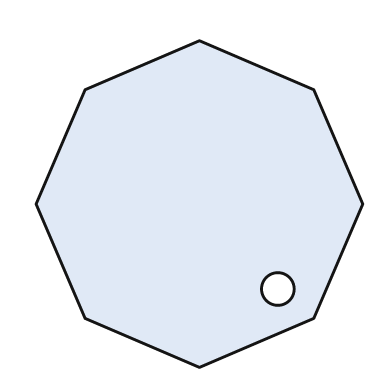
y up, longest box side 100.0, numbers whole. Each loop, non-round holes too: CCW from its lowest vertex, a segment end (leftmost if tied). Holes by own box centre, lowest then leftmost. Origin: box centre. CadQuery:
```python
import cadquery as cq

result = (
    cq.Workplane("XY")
    .moveTo(0.0, -50.0)
    .lineTo(35.0, -35.0)
    .lineTo(50.0, 0.0)
    .lineTo(35.0, 35.0)
    .lineTo(0.0, 50.0)
    .lineTo(-35.0, 35.0)
    .lineTo(-50.0, 0.0)
    .lineTo(-35.0, -35.0)
    .close()
    .moveTo(24.0, -26.0)
    .circle(5.0)
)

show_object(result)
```